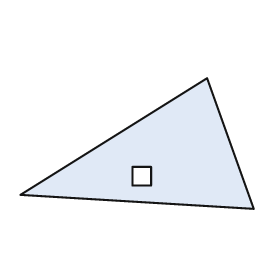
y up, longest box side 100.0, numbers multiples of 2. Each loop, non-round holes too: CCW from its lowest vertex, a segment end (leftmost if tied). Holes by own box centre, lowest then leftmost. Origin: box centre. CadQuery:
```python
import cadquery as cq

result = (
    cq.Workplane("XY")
    .moveTo(50.0, -28.0)
    .lineTo(30.0, 28.0)
    .lineTo(-50.0, -22.0)
    .close()
    .moveTo(-2.0, -18.0)
    .lineTo(6.0, -18.0)
    .lineTo(6.0, -10.0)
    .lineTo(-2.0, -10.0)
    .close()
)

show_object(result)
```